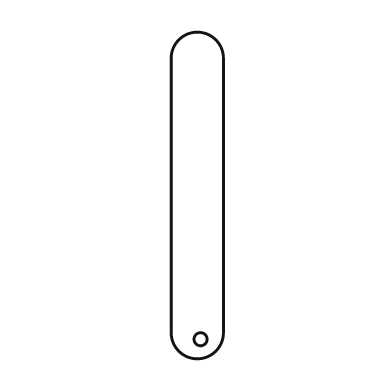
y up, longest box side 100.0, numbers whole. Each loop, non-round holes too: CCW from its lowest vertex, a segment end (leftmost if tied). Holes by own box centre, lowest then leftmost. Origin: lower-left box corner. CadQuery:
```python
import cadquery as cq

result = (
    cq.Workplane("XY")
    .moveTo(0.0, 8.0)
    .threePointArc((8.0, 0.0), (16.0, 8.0))
    .lineTo(16.0, 92.0)
    .threePointArc((8.0, 100.0), (0.0, 92.0))
    .close()
    .moveTo(9.0, 6.0)
    .circle(2.0)
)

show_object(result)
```